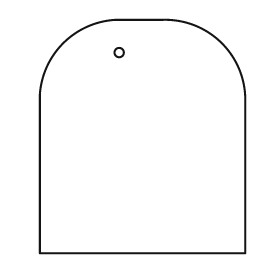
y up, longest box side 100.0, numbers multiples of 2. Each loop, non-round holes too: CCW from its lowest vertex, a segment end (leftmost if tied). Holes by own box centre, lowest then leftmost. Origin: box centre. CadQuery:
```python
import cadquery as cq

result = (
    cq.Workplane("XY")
    .moveTo(-44.0, -50.0)
    .lineTo(44.0, -50.0)
    .lineTo(44.0, 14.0)
    .threePointArc((34.0, 40.0), (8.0, 50.0))
    .lineTo(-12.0, 50.0)
    .threePointArc((-34.0, 40.0), (-44.0, 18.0))
    .close()
    .moveTo(-10.0, 36.0)
    .circle(2.0)
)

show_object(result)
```